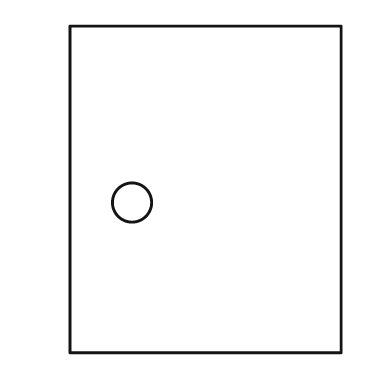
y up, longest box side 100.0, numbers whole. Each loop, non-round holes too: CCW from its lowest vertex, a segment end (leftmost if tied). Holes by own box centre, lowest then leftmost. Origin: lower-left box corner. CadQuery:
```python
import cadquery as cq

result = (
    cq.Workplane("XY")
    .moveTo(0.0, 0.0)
    .lineTo(83.0, 0.0)
    .lineTo(83.0, 100.0)
    .lineTo(0.0, 100.0)
    .close()
    .moveTo(19.0, 46.0)
    .circle(6.0)
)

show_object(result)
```